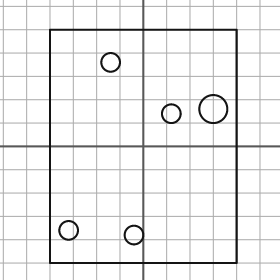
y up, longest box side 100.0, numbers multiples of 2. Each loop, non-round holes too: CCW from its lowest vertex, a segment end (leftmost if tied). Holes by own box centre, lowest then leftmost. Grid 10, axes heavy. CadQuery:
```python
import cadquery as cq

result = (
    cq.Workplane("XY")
    .moveTo(-40.0, -50.0)
    .lineTo(40.0, -50.0)
    .lineTo(40.0, 50.0)
    .lineTo(-40.0, 50.0)
    .close()
    .moveTo(-4.0, -38.0)
    .circle(4.0)
    .moveTo(-32.0, -36.0)
    .circle(4.0)
    .moveTo(12.0, 14.0)
    .circle(4.0)
    .moveTo(30.0, 16.0)
    .circle(6.0)
    .moveTo(-14.0, 36.0)
    .circle(4.0)
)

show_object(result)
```